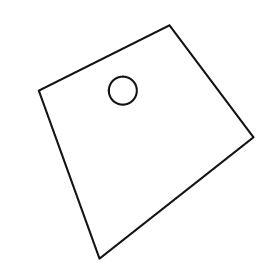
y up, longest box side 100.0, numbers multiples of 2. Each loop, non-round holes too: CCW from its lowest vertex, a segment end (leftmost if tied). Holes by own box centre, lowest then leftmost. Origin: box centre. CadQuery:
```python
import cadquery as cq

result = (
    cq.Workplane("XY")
    .moveTo(-20.0, -50.0)
    .lineTo(46.0, 2.0)
    .lineTo(10.0, 50.0)
    .lineTo(-46.0, 22.0)
    .close()
    .moveTo(-10.0, 22.0)
    .circle(6.0)
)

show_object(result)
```